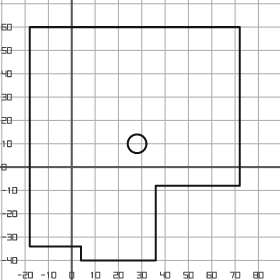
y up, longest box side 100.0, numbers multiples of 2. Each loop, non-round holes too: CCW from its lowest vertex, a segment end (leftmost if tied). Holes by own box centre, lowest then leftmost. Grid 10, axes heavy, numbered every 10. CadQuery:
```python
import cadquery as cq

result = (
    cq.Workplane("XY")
    .moveTo(4.0, -40.0)
    .lineTo(36.0, -40.0)
    .lineTo(36.0, -8.0)
    .lineTo(72.0, -8.0)
    .lineTo(72.0, 60.0)
    .lineTo(-18.0, 60.0)
    .lineTo(-18.0, -34.0)
    .lineTo(4.0, -34.0)
    .close()
    .moveTo(28.0, 10.0)
    .circle(4.0)
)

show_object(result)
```